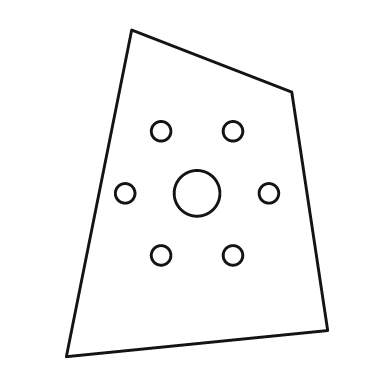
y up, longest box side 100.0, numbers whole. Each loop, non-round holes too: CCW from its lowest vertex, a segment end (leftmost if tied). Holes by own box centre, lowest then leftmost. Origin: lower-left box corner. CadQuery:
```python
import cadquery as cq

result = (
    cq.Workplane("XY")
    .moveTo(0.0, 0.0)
    .lineTo(80.0, 8.0)
    .lineTo(69.0, 81.0)
    .lineTo(20.0, 100.0)
    .close()
    .moveTo(29.0, 31.0)
    .circle(3.0)
    .moveTo(51.0, 31.0)
    .circle(3.0)
    .moveTo(18.0, 50.0)
    .circle(3.0)
    .moveTo(40.0, 50.0)
    .circle(7.0)
    .moveTo(62.0, 50.0)
    .circle(3.0)
    .moveTo(29.0, 69.0)
    .circle(3.0)
    .moveTo(51.0, 69.0)
    .circle(3.0)
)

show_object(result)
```